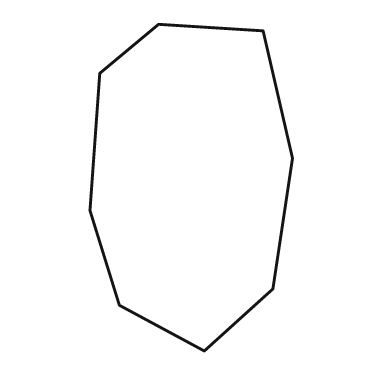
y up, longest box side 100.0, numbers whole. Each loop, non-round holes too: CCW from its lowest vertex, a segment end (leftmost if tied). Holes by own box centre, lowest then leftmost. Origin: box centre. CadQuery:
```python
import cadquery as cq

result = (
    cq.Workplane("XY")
    .moveTo(4.0, -50.0)
    .lineTo(25.0, -31.0)
    .lineTo(31.0, 9.0)
    .lineTo(22.0, 48.0)
    .lineTo(-10.0, 50.0)
    .lineTo(-28.0, 35.0)
    .lineTo(-31.0, -7.0)
    .lineTo(-22.0, -36.0)
    .close()
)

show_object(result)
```